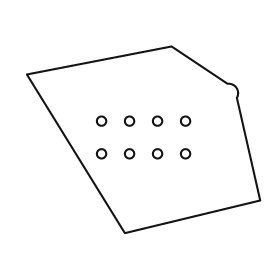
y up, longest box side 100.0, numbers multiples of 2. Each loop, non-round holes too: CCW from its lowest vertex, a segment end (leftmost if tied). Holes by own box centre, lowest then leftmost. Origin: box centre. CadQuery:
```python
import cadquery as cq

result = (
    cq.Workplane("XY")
    .moveTo(-8.0, -40.0)
    .lineTo(50.0, -26.0)
    .lineTo(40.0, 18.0)
    .threePointArc((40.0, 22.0), (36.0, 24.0))
    .lineTo(12.0, 40.0)
    .lineTo(-50.0, 28.0)
    .close()
    .moveTo(-18.0, -6.0)
    .circle(2.0)
    .moveTo(-6.0, -6.0)
    .circle(2.0)
    .moveTo(6.0, -6.0)
    .circle(2.0)
    .moveTo(18.0, -6.0)
    .circle(2.0)
    .moveTo(-18.0, 8.0)
    .circle(2.0)
    .moveTo(-6.0, 8.0)
    .circle(2.0)
    .moveTo(6.0, 8.0)
    .circle(2.0)
    .moveTo(18.0, 8.0)
    .circle(2.0)
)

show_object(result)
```